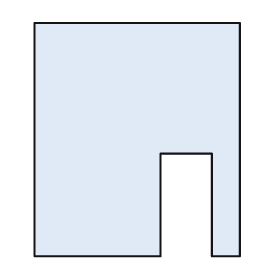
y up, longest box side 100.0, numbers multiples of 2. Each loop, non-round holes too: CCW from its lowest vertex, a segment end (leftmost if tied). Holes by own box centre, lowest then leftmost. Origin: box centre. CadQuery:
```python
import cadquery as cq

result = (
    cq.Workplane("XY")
    .moveTo(-44.0, -50.0)
    .lineTo(10.0, -50.0)
    .lineTo(10.0, -6.0)
    .lineTo(32.0, -6.0)
    .lineTo(32.0, -50.0)
    .lineTo(44.0, -50.0)
    .lineTo(44.0, 50.0)
    .lineTo(-44.0, 50.0)
    .close()
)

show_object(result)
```